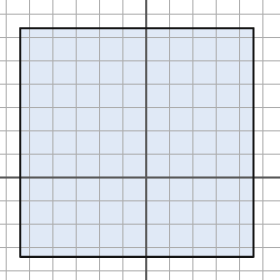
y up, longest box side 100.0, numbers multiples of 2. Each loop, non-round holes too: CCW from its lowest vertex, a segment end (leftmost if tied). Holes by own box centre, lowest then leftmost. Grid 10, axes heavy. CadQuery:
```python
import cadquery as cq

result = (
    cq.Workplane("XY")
    .moveTo(-54.0, -34.0)
    .lineTo(46.0, -34.0)
    .lineTo(46.0, 64.0)
    .lineTo(-54.0, 64.0)
    .close()
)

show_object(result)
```